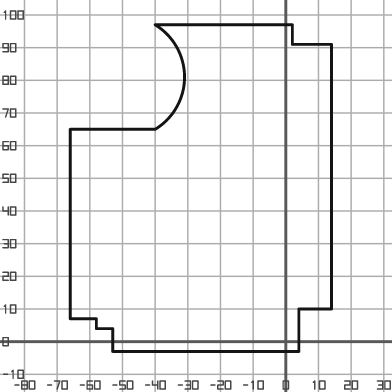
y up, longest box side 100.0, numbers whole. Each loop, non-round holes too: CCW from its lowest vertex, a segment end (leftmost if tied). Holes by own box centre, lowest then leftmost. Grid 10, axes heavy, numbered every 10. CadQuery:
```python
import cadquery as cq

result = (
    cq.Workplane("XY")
    .moveTo(-53.0, -3.0)
    .lineTo(4.0, -3.0)
    .lineTo(4.0, 10.0)
    .lineTo(14.0, 10.0)
    .lineTo(14.0, 91.0)
    .lineTo(2.0, 91.0)
    .lineTo(2.0, 97.0)
    .lineTo(-40.0, 97.0)
    .threePointArc((-31.0, 81.0), (-40.0, 65.0))
    .lineTo(-66.0, 65.0)
    .lineTo(-66.0, 7.0)
    .lineTo(-58.0, 7.0)
    .lineTo(-58.0, 4.0)
    .lineTo(-53.0, 4.0)
    .close()
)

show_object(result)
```